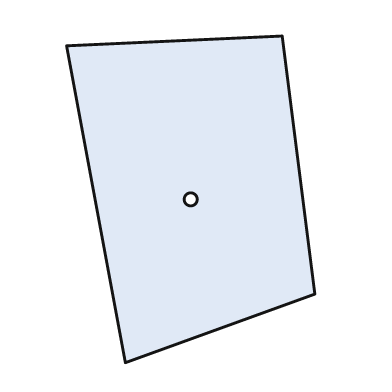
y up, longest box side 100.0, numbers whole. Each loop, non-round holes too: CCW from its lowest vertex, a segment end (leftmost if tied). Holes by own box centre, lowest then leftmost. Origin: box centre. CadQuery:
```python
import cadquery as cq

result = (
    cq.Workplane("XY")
    .moveTo(-20.0, -50.0)
    .lineTo(38.0, -29.0)
    .lineTo(28.0, 50.0)
    .lineTo(-38.0, 47.0)
    .close()
    .moveTo(0.0, 0.0)
    .circle(2.0)
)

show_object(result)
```